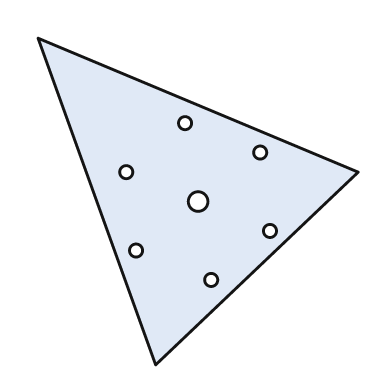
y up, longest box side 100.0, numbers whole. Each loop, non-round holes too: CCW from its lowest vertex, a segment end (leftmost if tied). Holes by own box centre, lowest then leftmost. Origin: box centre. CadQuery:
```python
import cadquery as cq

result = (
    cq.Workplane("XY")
    .moveTo(-13.0, -50.0)
    .lineTo(49.0, 9.0)
    .lineTo(-49.0, 50.0)
    .close()
    .moveTo(4.0, -24.0)
    .circle(2.0)
    .moveTo(-19.0, -15.0)
    .circle(2.0)
    .moveTo(22.0, -9.0)
    .circle(2.0)
    .moveTo(0.0, 0.0)
    .circle(3.0)
    .moveTo(-22.0, 9.0)
    .circle(2.0)
    .moveTo(19.0, 15.0)
    .circle(2.0)
    .moveTo(-4.0, 24.0)
    .circle(2.0)
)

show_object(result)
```